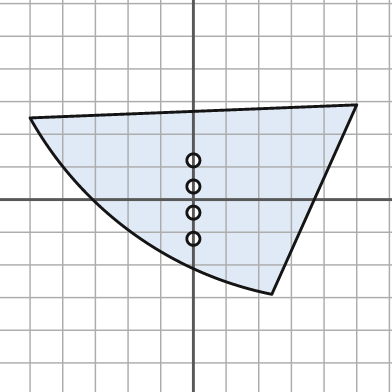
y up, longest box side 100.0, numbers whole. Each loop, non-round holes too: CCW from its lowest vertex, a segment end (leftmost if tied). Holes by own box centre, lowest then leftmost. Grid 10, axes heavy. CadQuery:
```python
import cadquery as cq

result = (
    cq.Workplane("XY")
    .moveTo(24.0, -29.0)
    .lineTo(50.0, 29.0)
    .lineTo(-50.0, 25.0)
    .threePointArc((-19.0, -10.0), (24.0, -29.0))
    .close()
    .moveTo(0.0, -12.0)
    .circle(2.0)
    .moveTo(0.0, -4.0)
    .circle(2.0)
    .moveTo(0.0, 4.0)
    .circle(2.0)
    .moveTo(0.0, 12.0)
    .circle(2.0)
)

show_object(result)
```